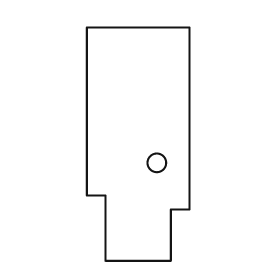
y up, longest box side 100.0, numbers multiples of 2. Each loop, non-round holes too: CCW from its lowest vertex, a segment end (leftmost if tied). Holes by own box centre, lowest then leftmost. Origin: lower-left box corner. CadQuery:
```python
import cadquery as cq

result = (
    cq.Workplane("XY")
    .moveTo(8.0, 0.0)
    .lineTo(36.0, 0.0)
    .lineTo(36.0, 22.0)
    .lineTo(44.0, 22.0)
    .lineTo(44.0, 100.0)
    .lineTo(0.0, 100.0)
    .lineTo(0.0, 28.0)
    .lineTo(8.0, 28.0)
    .close()
    .moveTo(30.0, 42.0)
    .circle(4.0)
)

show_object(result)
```